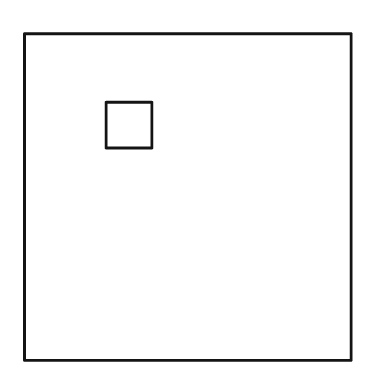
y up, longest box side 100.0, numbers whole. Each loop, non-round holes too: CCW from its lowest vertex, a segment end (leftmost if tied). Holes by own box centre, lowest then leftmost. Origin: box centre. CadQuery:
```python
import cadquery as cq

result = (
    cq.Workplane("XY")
    .moveTo(-50.0, -50.0)
    .lineTo(50.0, -50.0)
    .lineTo(50.0, 50.0)
    .lineTo(-50.0, 50.0)
    .close()
    .moveTo(-25.0, 15.0)
    .lineTo(-11.0, 15.0)
    .lineTo(-11.0, 29.0)
    .lineTo(-25.0, 29.0)
    .close()
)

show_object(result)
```